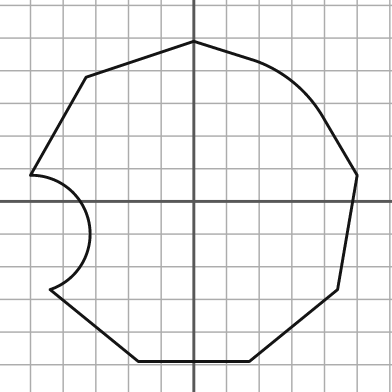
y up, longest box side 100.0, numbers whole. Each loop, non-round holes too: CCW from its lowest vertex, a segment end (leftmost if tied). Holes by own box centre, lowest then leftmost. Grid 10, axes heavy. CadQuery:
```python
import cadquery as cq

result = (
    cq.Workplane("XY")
    .moveTo(-17.0, -49.0)
    .lineTo(17.0, -49.0)
    .lineTo(44.0, -27.0)
    .lineTo(50.0, 8.0)
    .lineTo(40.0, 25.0)
    .threePointArc((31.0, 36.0), (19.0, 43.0))
    .lineTo(0.0, 49.0)
    .lineTo(-33.0, 38.0)
    .lineTo(-50.0, 8.0)
    .threePointArc((-32.0, -7.0), (-44.0, -27.0))
    .close()
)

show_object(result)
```